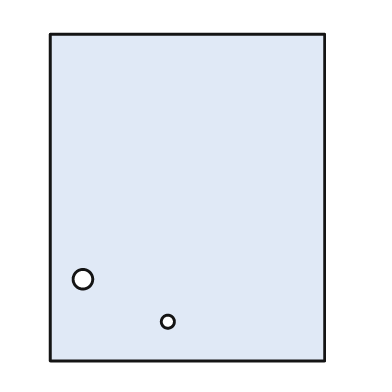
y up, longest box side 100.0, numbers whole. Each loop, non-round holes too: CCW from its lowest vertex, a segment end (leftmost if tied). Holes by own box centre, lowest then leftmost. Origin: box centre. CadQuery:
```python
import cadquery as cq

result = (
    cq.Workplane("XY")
    .moveTo(-42.0, -50.0)
    .lineTo(42.0, -50.0)
    .lineTo(42.0, 50.0)
    .lineTo(-42.0, 50.0)
    .close()
    .moveTo(-6.0, -38.0)
    .circle(2.0)
    .moveTo(-32.0, -25.0)
    .circle(3.0)
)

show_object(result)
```